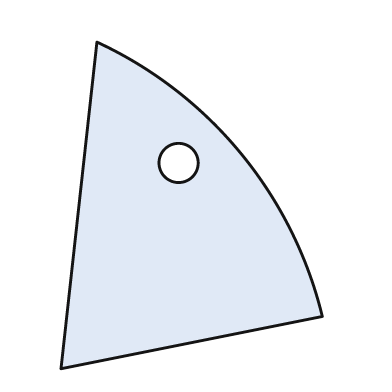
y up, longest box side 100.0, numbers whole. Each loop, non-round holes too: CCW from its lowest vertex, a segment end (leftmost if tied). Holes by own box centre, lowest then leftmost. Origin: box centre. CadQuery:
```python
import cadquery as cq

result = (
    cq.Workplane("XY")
    .moveTo(-40.0, -50.0)
    .lineTo(40.0, -34.0)
    .threePointArc((15.0, 16.0), (-29.0, 50.0))
    .close()
    .moveTo(-4.0, 13.0)
    .circle(6.0)
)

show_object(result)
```